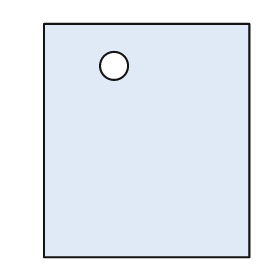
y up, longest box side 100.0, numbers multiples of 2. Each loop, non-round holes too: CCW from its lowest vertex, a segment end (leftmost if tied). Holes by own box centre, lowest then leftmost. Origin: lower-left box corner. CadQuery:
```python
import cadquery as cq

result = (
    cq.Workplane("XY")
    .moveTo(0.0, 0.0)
    .lineTo(88.0, 0.0)
    .lineTo(88.0, 100.0)
    .lineTo(0.0, 100.0)
    .close()
    .moveTo(30.0, 82.0)
    .circle(6.0)
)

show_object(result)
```